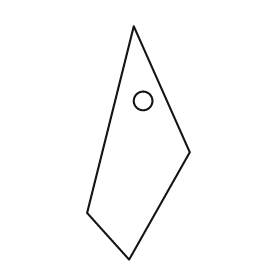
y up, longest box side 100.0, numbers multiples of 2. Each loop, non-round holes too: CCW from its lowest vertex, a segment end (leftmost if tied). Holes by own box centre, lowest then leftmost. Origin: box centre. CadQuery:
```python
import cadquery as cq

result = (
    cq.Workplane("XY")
    .moveTo(-4.0, -50.0)
    .lineTo(22.0, -4.0)
    .lineTo(-2.0, 50.0)
    .lineTo(-22.0, -30.0)
    .close()
    .moveTo(2.0, 18.0)
    .circle(4.0)
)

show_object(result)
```